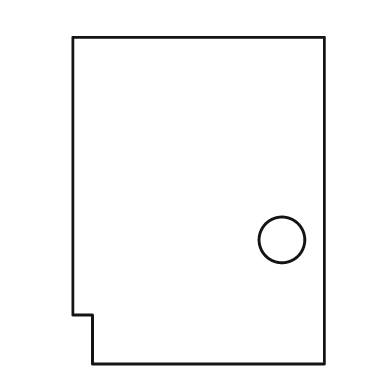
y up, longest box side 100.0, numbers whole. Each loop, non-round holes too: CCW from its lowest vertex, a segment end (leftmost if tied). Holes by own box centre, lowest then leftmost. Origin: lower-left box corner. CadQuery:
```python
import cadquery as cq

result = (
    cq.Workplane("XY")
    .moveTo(6.0, 0.0)
    .lineTo(77.0, 0.0)
    .lineTo(77.0, 100.0)
    .lineTo(0.0, 100.0)
    .lineTo(0.0, 15.0)
    .lineTo(6.0, 15.0)
    .close()
    .moveTo(64.0, 38.0)
    .circle(7.0)
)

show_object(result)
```